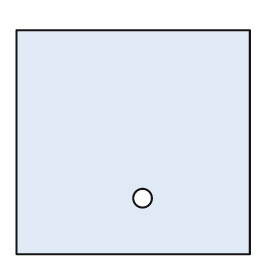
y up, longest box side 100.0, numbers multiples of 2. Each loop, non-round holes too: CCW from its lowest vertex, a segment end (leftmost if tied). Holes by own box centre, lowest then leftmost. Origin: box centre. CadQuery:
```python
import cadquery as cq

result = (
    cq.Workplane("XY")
    .moveTo(-50.0, -48.0)
    .lineTo(50.0, -48.0)
    .lineTo(50.0, 48.0)
    .lineTo(-50.0, 48.0)
    .close()
    .moveTo(4.0, -24.0)
    .circle(4.0)
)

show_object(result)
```